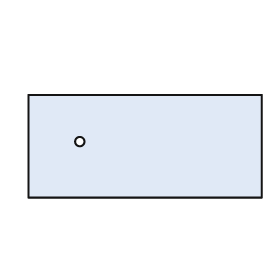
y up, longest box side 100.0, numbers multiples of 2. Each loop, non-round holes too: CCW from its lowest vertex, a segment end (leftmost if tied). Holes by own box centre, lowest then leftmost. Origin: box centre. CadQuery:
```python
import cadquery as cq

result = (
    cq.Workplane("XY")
    .moveTo(-50.0, -22.0)
    .lineTo(50.0, -22.0)
    .lineTo(50.0, 22.0)
    .lineTo(-50.0, 22.0)
    .close()
    .moveTo(-28.0, 2.0)
    .circle(2.0)
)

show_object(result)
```